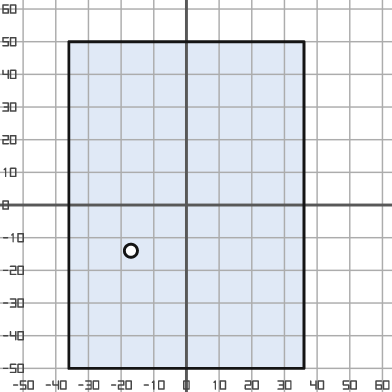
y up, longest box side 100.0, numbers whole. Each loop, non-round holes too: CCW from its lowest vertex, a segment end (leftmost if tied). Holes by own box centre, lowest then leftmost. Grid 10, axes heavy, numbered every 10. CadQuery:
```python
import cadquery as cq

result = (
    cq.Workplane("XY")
    .moveTo(-36.0, -50.0)
    .lineTo(36.0, -50.0)
    .lineTo(36.0, 50.0)
    .lineTo(-36.0, 50.0)
    .close()
    .moveTo(-17.0, -14.0)
    .circle(2.0)
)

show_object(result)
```